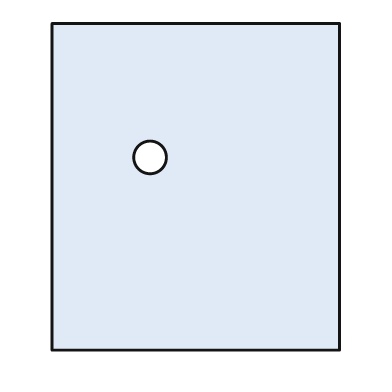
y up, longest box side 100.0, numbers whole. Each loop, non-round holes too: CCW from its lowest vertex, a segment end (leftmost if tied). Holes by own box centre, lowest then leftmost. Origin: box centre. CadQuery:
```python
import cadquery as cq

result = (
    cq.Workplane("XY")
    .moveTo(-44.0, -50.0)
    .lineTo(44.0, -50.0)
    .lineTo(44.0, 50.0)
    .lineTo(-44.0, 50.0)
    .close()
    .moveTo(-14.0, 9.0)
    .circle(5.0)
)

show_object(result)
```